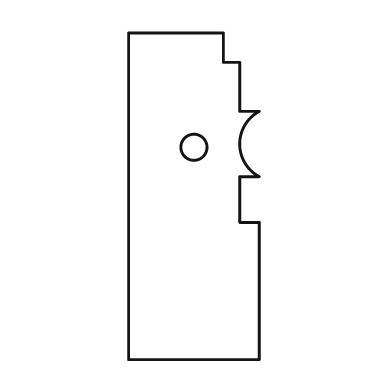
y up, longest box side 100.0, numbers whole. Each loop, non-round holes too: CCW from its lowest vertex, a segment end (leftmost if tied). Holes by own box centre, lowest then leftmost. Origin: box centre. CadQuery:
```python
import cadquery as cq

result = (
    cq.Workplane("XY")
    .moveTo(-20.0, -50.0)
    .lineTo(20.0, -50.0)
    .lineTo(20.0, -8.0)
    .lineTo(14.0, -8.0)
    .lineTo(14.0, 6.0)
    .lineTo(20.0, 6.0)
    .threePointArc((14.0, 16.0), (20.0, 26.0))
    .lineTo(14.0, 26.0)
    .lineTo(14.0, 41.0)
    .lineTo(9.0, 41.0)
    .lineTo(9.0, 50.0)
    .lineTo(-20.0, 50.0)
    .close()
    .moveTo(0.0, 15.0)
    .circle(4.0)
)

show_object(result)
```